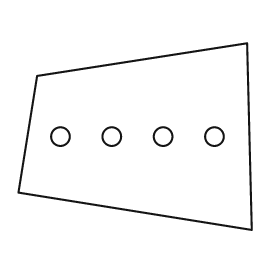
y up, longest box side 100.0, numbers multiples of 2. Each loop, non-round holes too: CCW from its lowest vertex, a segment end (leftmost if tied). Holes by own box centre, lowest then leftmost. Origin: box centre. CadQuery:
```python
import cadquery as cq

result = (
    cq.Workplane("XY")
    .moveTo(50.0, -40.0)
    .lineTo(48.0, 40.0)
    .lineTo(-42.0, 26.0)
    .lineTo(-50.0, -24.0)
    .close()
    .moveTo(-32.0, 0.0)
    .circle(4.0)
    .moveTo(-10.0, 0.0)
    .circle(4.0)
    .moveTo(12.0, 0.0)
    .circle(4.0)
    .moveTo(34.0, 0.0)
    .circle(4.0)
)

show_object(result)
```